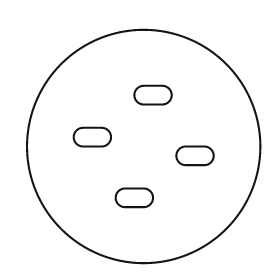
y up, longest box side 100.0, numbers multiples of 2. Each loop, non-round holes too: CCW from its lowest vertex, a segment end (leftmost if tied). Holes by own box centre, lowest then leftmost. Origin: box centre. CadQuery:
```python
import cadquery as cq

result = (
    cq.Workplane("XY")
    .moveTo(0.0, 0.0)
    .circle(50.0)
    .moveTo(-8.0, -26.0)
    .lineTo(0.0, -26.0)
    .threePointArc((4.0, -22.0), (0.0, -18.0))
    .lineTo(-8.0, -18.0)
    .threePointArc((-12.0, -22.0), (-8.0, -26.0))
    .close()
    .moveTo(18.0, -8.0)
    .lineTo(26.0, -8.0)
    .threePointArc((30.0, -4.0), (26.0, 0.0))
    .lineTo(18.0, 0.0)
    .threePointArc((14.0, -4.0), (18.0, -8.0))
    .close()
    .moveTo(-26.0, 0.0)
    .lineTo(-18.0, 0.0)
    .threePointArc((-14.0, 4.0), (-18.0, 8.0))
    .lineTo(-26.0, 8.0)
    .threePointArc((-30.0, 4.0), (-26.0, 0.0))
    .close()
    .moveTo(0.0, 18.0)
    .lineTo(8.0, 18.0)
    .threePointArc((12.0, 22.0), (8.0, 26.0))
    .lineTo(0.0, 26.0)
    .threePointArc((-4.0, 22.0), (0.0, 18.0))
    .close()
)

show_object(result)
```